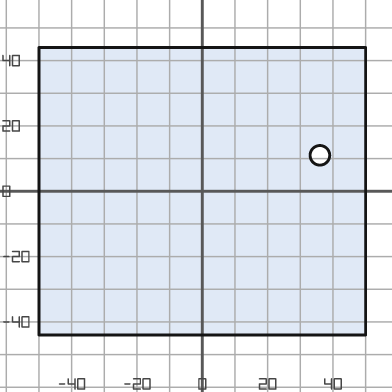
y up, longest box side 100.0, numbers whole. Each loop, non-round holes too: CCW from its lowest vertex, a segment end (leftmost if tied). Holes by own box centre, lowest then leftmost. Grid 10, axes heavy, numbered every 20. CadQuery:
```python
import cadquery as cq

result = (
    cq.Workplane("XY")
    .moveTo(-50.0, -44.0)
    .lineTo(50.0, -44.0)
    .lineTo(50.0, 44.0)
    .lineTo(-50.0, 44.0)
    .close()
    .moveTo(36.0, 11.0)
    .circle(3.0)
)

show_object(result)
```